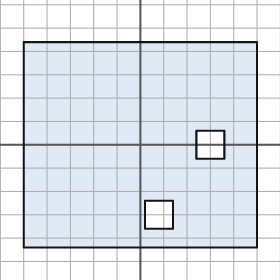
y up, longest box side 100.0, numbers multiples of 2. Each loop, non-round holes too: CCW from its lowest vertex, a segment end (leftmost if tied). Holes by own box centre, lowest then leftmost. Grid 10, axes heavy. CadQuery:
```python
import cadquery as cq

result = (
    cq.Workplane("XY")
    .moveTo(-50.0, -44.0)
    .lineTo(50.0, -44.0)
    .lineTo(50.0, 44.0)
    .lineTo(-50.0, 44.0)
    .close()
    .moveTo(2.0, -36.0)
    .lineTo(14.0, -36.0)
    .lineTo(14.0, -24.0)
    .lineTo(2.0, -24.0)
    .close()
    .moveTo(24.0, -6.0)
    .lineTo(36.0, -6.0)
    .lineTo(36.0, 6.0)
    .lineTo(24.0, 6.0)
    .close()
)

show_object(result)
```